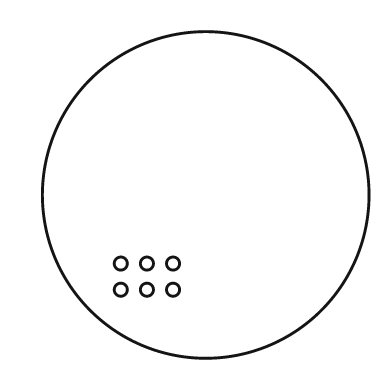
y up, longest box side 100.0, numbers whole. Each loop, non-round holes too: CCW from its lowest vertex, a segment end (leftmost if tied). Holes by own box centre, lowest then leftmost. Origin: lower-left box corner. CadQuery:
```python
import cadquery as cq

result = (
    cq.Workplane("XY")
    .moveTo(50.0, 50.0)
    .circle(50.0)
    .moveTo(24.0, 21.0)
    .circle(2.0)
    .moveTo(32.0, 21.0)
    .circle(2.0)
    .moveTo(40.0, 21.0)
    .circle(2.0)
    .moveTo(24.0, 29.0)
    .circle(2.0)
    .moveTo(32.0, 29.0)
    .circle(2.0)
    .moveTo(40.0, 29.0)
    .circle(2.0)
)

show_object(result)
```